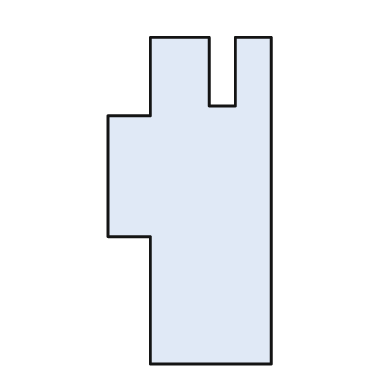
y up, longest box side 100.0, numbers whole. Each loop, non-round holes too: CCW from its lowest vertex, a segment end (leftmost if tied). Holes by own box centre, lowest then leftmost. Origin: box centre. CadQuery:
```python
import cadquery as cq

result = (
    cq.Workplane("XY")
    .moveTo(-12.0, -50.0)
    .lineTo(25.0, -50.0)
    .lineTo(25.0, 50.0)
    .lineTo(14.0, 50.0)
    .lineTo(14.0, 29.0)
    .lineTo(6.0, 29.0)
    .lineTo(6.0, 50.0)
    .lineTo(-12.0, 50.0)
    .lineTo(-12.0, 26.0)
    .lineTo(-25.0, 26.0)
    .lineTo(-25.0, -11.0)
    .lineTo(-12.0, -11.0)
    .close()
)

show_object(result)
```